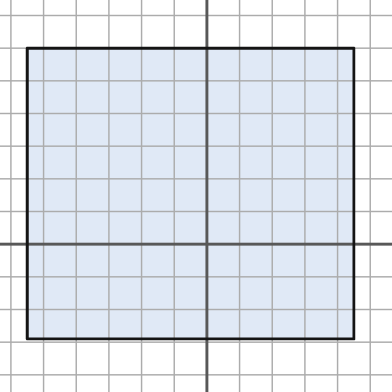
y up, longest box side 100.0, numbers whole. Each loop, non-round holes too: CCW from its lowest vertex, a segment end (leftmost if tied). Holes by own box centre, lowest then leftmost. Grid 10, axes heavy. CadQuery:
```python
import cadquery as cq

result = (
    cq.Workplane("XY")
    .moveTo(-55.0, -29.0)
    .lineTo(45.0, -29.0)
    .lineTo(45.0, 60.0)
    .lineTo(-55.0, 60.0)
    .close()
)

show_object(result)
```